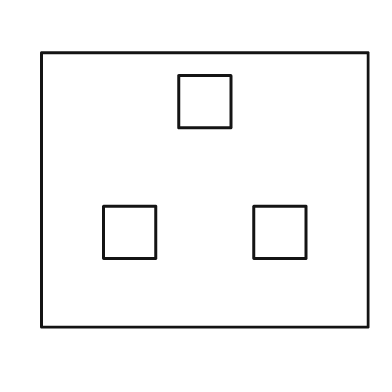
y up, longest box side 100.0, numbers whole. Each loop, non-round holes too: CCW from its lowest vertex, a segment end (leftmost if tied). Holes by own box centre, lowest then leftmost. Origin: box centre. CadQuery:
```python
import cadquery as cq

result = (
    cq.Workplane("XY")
    .moveTo(-50.0, -42.0)
    .lineTo(50.0, -42.0)
    .lineTo(50.0, 42.0)
    .lineTo(-50.0, 42.0)
    .close()
    .moveTo(-31.0, -21.0)
    .lineTo(-15.0, -21.0)
    .lineTo(-15.0, -5.0)
    .lineTo(-31.0, -5.0)
    .close()
    .moveTo(15.0, -21.0)
    .lineTo(31.0, -21.0)
    .lineTo(31.0, -5.0)
    .lineTo(15.0, -5.0)
    .close()
    .moveTo(-8.0, 19.0)
    .lineTo(8.0, 19.0)
    .lineTo(8.0, 35.0)
    .lineTo(-8.0, 35.0)
    .close()
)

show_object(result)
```